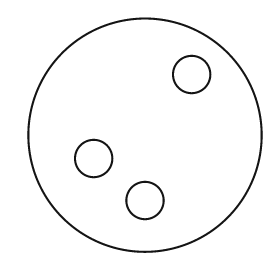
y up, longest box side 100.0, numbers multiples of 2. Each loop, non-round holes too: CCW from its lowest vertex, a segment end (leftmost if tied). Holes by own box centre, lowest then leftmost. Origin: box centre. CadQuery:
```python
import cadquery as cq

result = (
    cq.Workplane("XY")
    .moveTo(0.0, 0.0)
    .circle(50.0)
    .moveTo(0.0, -28.0)
    .circle(8.0)
    .moveTo(-22.0, -10.0)
    .circle(8.0)
    .moveTo(20.0, 26.0)
    .circle(8.0)
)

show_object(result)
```